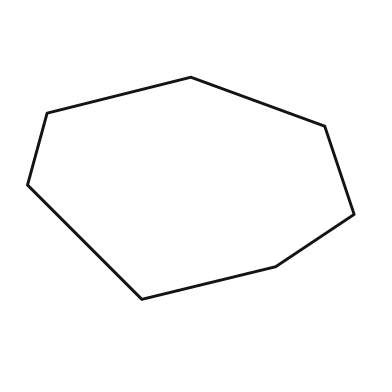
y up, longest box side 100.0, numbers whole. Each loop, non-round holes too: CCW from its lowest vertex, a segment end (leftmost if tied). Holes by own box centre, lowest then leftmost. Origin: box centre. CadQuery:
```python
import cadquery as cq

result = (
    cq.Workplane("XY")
    .moveTo(-15.0, -34.0)
    .lineTo(26.0, -24.0)
    .lineTo(50.0, -8.0)
    .lineTo(41.0, 19.0)
    .lineTo(0.0, 34.0)
    .lineTo(-44.0, 23.0)
    .lineTo(-50.0, 1.0)
    .close()
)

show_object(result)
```